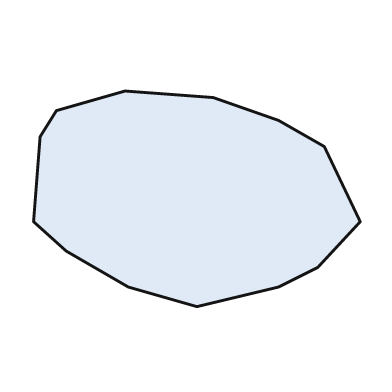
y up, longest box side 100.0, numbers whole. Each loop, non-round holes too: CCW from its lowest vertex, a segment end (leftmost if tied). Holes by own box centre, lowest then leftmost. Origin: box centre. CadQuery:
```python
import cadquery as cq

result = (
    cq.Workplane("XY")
    .moveTo(0.0, -33.0)
    .lineTo(25.0, -27.0)
    .lineTo(37.0, -21.0)
    .lineTo(50.0, -7.0)
    .lineTo(39.0, 16.0)
    .lineTo(25.0, 24.0)
    .lineTo(5.0, 31.0)
    .lineTo(-22.0, 33.0)
    .lineTo(-43.0, 27.0)
    .lineTo(-48.0, 19.0)
    .lineTo(-50.0, -7.0)
    .lineTo(-40.0, -16.0)
    .lineTo(-21.0, -27.0)
    .close()
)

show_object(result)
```